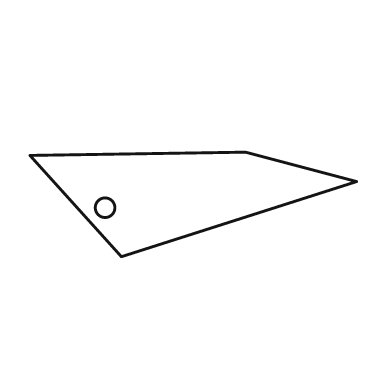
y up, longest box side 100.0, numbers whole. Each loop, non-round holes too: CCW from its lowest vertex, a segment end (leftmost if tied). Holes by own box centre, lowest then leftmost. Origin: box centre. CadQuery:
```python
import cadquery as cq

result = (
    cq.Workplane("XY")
    .moveTo(-22.0, -16.0)
    .lineTo(50.0, 7.0)
    .lineTo(16.0, 16.0)
    .lineTo(-50.0, 15.0)
    .close()
    .moveTo(-27.0, -1.0)
    .circle(3.0)
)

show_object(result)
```